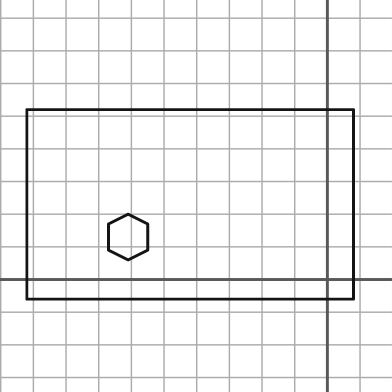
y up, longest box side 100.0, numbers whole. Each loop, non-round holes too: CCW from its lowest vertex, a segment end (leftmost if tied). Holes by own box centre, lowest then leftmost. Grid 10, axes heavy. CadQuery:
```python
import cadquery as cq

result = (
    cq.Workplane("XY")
    .moveTo(-92.0, -6.0)
    .lineTo(8.0, -6.0)
    .lineTo(8.0, 52.0)
    .lineTo(-92.0, 52.0)
    .close()
    .moveTo(-61.0, 6.0)
    .lineTo(-55.0, 9.0)
    .lineTo(-55.0, 17.0)
    .lineTo(-61.0, 20.0)
    .lineTo(-67.0, 17.0)
    .lineTo(-67.0, 9.0)
    .close()
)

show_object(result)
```